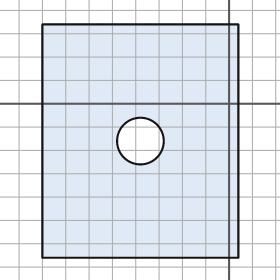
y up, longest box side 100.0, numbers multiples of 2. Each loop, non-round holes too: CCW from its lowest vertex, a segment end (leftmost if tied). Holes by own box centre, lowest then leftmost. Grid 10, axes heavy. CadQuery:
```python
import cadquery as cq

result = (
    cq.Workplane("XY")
    .moveTo(-80.0, -66.0)
    .lineTo(4.0, -66.0)
    .lineTo(4.0, 34.0)
    .lineTo(-80.0, 34.0)
    .close()
    .moveTo(-38.0, -16.0)
    .circle(10.0)
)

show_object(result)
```